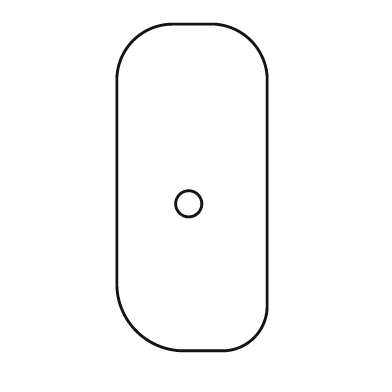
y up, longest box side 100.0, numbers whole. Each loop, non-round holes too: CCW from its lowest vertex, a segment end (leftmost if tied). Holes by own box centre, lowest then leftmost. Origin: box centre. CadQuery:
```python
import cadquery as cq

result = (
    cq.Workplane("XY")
    .moveTo(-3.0, -50.0)
    .lineTo(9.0, -50.0)
    .threePointArc((19.0, -46.0), (23.0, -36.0))
    .lineTo(23.0, 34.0)
    .threePointArc((18.0, 45.0), (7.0, 50.0))
    .lineTo(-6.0, 50.0)
    .threePointArc((-18.0, 45.0), (-23.0, 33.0))
    .lineTo(-23.0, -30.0)
    .threePointArc((-17.0, -44.0), (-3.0, -50.0))
    .close()
    .moveTo(-1.0, -5.0)
    .circle(4.0)
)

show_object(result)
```